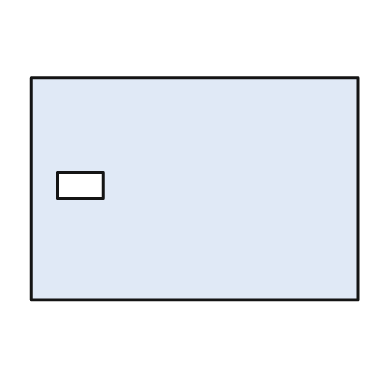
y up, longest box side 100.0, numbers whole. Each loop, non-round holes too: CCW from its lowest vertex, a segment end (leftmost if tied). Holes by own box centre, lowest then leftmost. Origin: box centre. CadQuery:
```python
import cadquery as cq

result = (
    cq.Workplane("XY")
    .moveTo(-50.0, -34.0)
    .lineTo(50.0, -34.0)
    .lineTo(50.0, 34.0)
    .lineTo(-50.0, 34.0)
    .close()
    .moveTo(-42.0, -3.0)
    .lineTo(-28.0, -3.0)
    .lineTo(-28.0, 5.0)
    .lineTo(-42.0, 5.0)
    .close()
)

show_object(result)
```